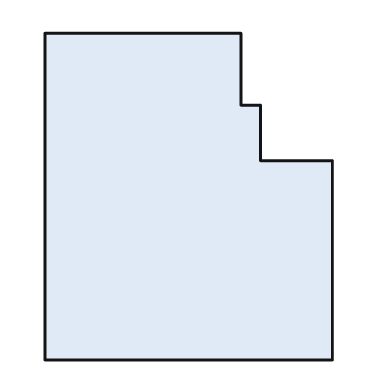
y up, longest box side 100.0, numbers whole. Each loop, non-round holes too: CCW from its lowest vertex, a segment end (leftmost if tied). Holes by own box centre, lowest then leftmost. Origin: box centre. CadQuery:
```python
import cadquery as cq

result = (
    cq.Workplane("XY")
    .moveTo(-44.0, -50.0)
    .lineTo(44.0, -50.0)
    .lineTo(44.0, 11.0)
    .lineTo(22.0, 11.0)
    .lineTo(22.0, 28.0)
    .lineTo(16.0, 28.0)
    .lineTo(16.0, 50.0)
    .lineTo(-44.0, 50.0)
    .close()
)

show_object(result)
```